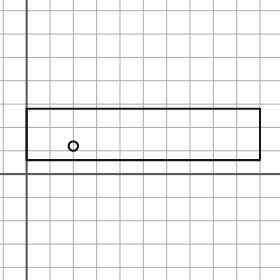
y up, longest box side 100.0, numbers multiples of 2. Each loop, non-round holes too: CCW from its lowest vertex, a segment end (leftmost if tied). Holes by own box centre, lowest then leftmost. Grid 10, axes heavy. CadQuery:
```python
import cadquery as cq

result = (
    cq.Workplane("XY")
    .moveTo(0.0, 6.0)
    .lineTo(100.0, 6.0)
    .lineTo(100.0, 28.0)
    .lineTo(0.0, 28.0)
    .close()
    .moveTo(20.0, 12.0)
    .circle(2.0)
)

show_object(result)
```